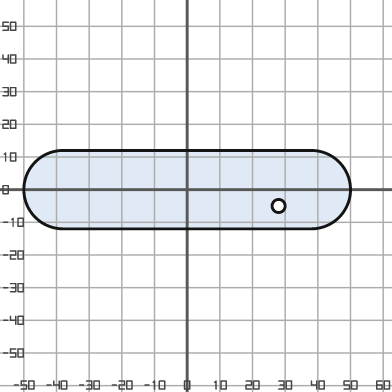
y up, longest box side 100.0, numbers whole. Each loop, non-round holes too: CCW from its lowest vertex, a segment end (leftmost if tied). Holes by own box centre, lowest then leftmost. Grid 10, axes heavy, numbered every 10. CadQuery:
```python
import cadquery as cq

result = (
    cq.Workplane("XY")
    .moveTo(-38.0, -12.0)
    .lineTo(38.0, -12.0)
    .threePointArc((50.0, 0.0), (38.0, 12.0))
    .lineTo(-38.0, 12.0)
    .threePointArc((-50.0, 0.0), (-38.0, -12.0))
    .close()
    .moveTo(28.0, -5.0)
    .circle(2.0)
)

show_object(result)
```